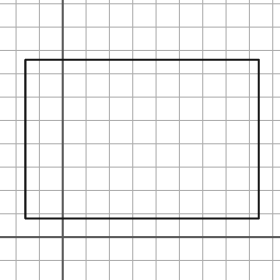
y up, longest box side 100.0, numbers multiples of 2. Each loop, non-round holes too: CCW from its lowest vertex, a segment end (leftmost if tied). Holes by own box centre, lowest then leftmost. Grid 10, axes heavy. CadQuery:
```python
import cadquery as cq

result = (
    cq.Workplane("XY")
    .moveTo(-16.0, 8.0)
    .lineTo(84.0, 8.0)
    .lineTo(84.0, 76.0)
    .lineTo(-16.0, 76.0)
    .close()
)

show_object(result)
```